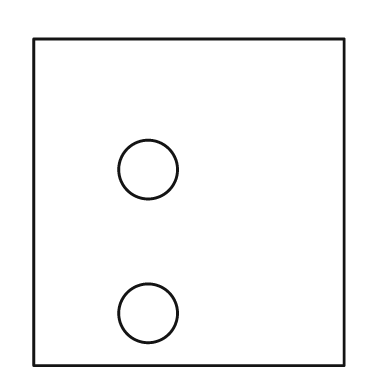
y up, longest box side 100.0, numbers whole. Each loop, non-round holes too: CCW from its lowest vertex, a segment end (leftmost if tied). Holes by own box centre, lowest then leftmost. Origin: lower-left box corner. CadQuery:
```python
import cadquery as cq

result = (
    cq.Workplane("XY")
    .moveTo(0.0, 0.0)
    .lineTo(95.0, 0.0)
    .lineTo(95.0, 100.0)
    .lineTo(0.0, 100.0)
    .close()
    .moveTo(35.0, 16.0)
    .circle(9.0)
    .moveTo(35.0, 60.0)
    .circle(9.0)
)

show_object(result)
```